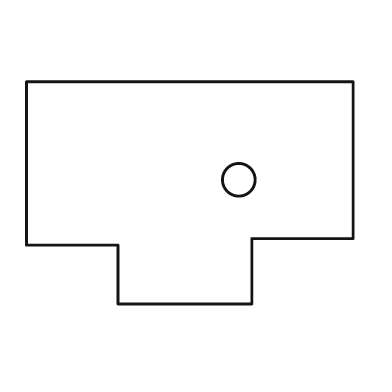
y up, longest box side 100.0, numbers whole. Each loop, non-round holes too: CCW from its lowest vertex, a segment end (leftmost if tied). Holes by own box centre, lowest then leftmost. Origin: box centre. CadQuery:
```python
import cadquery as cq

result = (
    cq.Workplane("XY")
    .moveTo(-22.0, -34.0)
    .lineTo(19.0, -34.0)
    .lineTo(19.0, -14.0)
    .lineTo(50.0, -14.0)
    .lineTo(50.0, 34.0)
    .lineTo(-50.0, 34.0)
    .lineTo(-50.0, -16.0)
    .lineTo(-22.0, -16.0)
    .close()
    .moveTo(15.0, 4.0)
    .circle(5.0)
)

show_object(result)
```